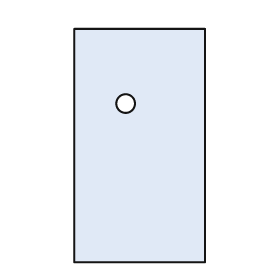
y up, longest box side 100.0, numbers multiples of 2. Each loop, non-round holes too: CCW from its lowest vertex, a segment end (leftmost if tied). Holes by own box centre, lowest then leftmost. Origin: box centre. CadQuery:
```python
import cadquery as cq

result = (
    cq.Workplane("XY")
    .moveTo(-28.0, -50.0)
    .lineTo(28.0, -50.0)
    .lineTo(28.0, 50.0)
    .lineTo(-28.0, 50.0)
    .close()
    .moveTo(-6.0, 18.0)
    .circle(4.0)
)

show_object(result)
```